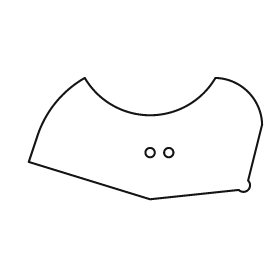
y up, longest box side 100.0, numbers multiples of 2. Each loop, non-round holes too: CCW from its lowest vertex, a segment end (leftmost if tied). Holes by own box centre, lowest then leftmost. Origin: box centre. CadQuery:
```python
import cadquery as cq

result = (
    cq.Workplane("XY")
    .moveTo(2.0, -26.0)
    .lineTo(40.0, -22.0)
    .threePointArc((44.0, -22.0), (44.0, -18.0))
    .lineTo(50.0, 6.0)
    .threePointArc((44.0, 20.0), (30.0, 26.0))
    .threePointArc((2.0, 10.0), (-26.0, 26.0))
    .threePointArc((-38.0, 16.0), (-46.0, 2.0))
    .lineTo(-50.0, -10.0)
    .close()
    .moveTo(2.0, -6.0)
    .circle(2.0)
    .moveTo(10.0, -6.0)
    .circle(2.0)
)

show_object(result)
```